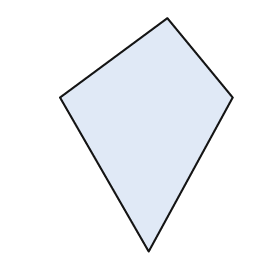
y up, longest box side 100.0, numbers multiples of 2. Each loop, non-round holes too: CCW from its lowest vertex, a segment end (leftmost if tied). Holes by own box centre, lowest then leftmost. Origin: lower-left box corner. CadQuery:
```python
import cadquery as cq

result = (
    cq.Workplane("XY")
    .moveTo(38.0, 0.0)
    .lineTo(74.0, 66.0)
    .lineTo(46.0, 100.0)
    .lineTo(0.0, 66.0)
    .close()
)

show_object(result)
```